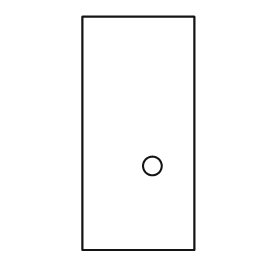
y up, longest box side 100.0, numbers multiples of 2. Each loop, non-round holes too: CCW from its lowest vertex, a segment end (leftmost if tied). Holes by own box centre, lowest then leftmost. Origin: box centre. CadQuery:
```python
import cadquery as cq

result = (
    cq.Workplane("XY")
    .moveTo(-24.0, -50.0)
    .lineTo(24.0, -50.0)
    .lineTo(24.0, 50.0)
    .lineTo(-24.0, 50.0)
    .close()
    .moveTo(6.0, -14.0)
    .circle(4.0)
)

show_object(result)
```